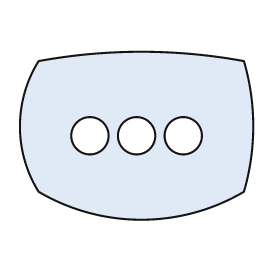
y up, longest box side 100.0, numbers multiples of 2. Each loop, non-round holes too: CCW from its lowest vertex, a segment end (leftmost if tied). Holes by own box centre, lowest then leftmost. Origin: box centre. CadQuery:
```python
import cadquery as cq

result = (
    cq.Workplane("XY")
    .moveTo(-42.0, -24.0)
    .threePointArc((2.0, -36.0), (46.0, -24.0))
    .threePointArc((50.0, 4.0), (46.0, 32.0))
    .threePointArc((2.0, 36.0), (-42.0, 32.0))
    .threePointArc((-50.0, 4.0), (-42.0, -24.0))
    .close()
    .moveTo(-20.0, 0.0)
    .circle(8.0)
    .moveTo(0.0, 0.0)
    .circle(8.0)
    .moveTo(20.0, 0.0)
    .circle(8.0)
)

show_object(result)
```